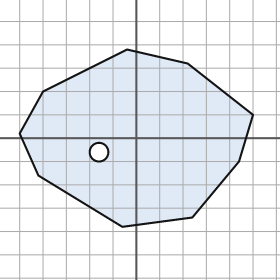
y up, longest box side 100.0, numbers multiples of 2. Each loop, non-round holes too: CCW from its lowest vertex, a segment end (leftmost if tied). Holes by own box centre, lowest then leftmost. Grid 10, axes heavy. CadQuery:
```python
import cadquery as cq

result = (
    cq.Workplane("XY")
    .moveTo(-6.0, -38.0)
    .lineTo(24.0, -34.0)
    .lineTo(44.0, -10.0)
    .lineTo(50.0, 10.0)
    .lineTo(22.0, 32.0)
    .lineTo(-4.0, 38.0)
    .lineTo(-40.0, 20.0)
    .lineTo(-50.0, 2.0)
    .lineTo(-42.0, -16.0)
    .close()
    .moveTo(-16.0, -6.0)
    .circle(4.0)
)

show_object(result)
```